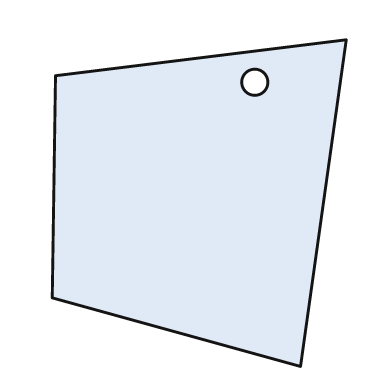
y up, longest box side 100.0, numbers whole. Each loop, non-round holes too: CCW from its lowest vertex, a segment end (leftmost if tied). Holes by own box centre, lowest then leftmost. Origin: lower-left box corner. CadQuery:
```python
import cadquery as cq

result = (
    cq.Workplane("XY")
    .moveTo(76.0, 0.0)
    .lineTo(90.0, 100.0)
    .lineTo(1.0, 89.0)
    .lineTo(0.0, 21.0)
    .close()
    .moveTo(62.0, 87.0)
    .circle(4.0)
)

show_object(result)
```